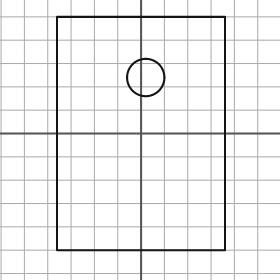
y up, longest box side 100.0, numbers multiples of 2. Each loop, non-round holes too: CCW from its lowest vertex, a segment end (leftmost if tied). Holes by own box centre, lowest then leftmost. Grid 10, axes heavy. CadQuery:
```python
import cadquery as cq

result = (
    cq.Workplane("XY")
    .moveTo(-36.0, -50.0)
    .lineTo(36.0, -50.0)
    .lineTo(36.0, 50.0)
    .lineTo(-36.0, 50.0)
    .close()
    .moveTo(2.0, 24.0)
    .circle(8.0)
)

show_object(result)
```